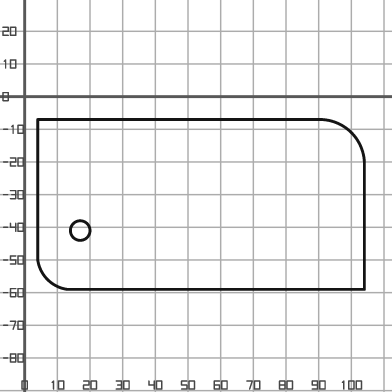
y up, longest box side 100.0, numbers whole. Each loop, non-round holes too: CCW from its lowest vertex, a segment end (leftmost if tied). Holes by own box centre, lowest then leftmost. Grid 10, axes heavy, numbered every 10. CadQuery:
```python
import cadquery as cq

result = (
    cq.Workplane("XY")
    .moveTo(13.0, -59.0)
    .lineTo(104.0, -59.0)
    .lineTo(104.0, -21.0)
    .threePointArc((100.0, -11.0), (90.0, -7.0))
    .lineTo(4.0, -7.0)
    .lineTo(4.0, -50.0)
    .threePointArc((7.0, -56.0), (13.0, -59.0))
    .close()
    .moveTo(17.0, -41.0)
    .circle(3.0)
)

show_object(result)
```